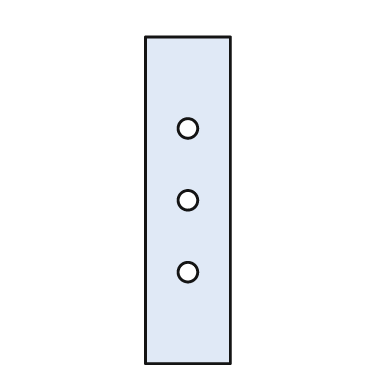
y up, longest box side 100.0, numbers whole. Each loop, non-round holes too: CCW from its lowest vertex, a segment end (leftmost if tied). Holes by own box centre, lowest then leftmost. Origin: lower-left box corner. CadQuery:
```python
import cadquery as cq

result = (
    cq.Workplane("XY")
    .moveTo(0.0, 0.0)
    .lineTo(26.0, 0.0)
    .lineTo(26.0, 100.0)
    .lineTo(0.0, 100.0)
    .close()
    .moveTo(13.0, 28.0)
    .circle(3.0)
    .moveTo(13.0, 50.0)
    .circle(3.0)
    .moveTo(13.0, 72.0)
    .circle(3.0)
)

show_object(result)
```